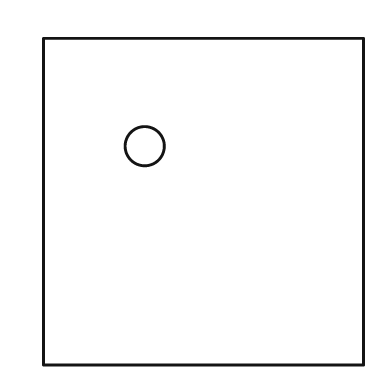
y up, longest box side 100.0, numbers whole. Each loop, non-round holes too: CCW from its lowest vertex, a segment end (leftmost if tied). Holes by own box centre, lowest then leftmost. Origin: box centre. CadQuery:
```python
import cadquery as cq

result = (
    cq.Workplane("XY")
    .moveTo(-49.0, -50.0)
    .lineTo(49.0, -50.0)
    .lineTo(49.0, 50.0)
    .lineTo(-49.0, 50.0)
    .close()
    .moveTo(-18.0, 17.0)
    .circle(6.0)
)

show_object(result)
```